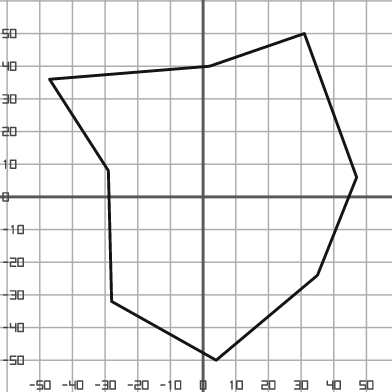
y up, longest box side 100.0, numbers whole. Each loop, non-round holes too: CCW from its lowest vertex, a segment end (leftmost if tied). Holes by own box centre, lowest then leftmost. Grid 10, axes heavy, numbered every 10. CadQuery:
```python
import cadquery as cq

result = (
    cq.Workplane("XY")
    .moveTo(4.0, -50.0)
    .lineTo(35.0, -24.0)
    .lineTo(47.0, 6.0)
    .lineTo(31.0, 50.0)
    .lineTo(2.0, 40.0)
    .lineTo(-47.0, 36.0)
    .lineTo(-29.0, 8.0)
    .lineTo(-28.0, -32.0)
    .close()
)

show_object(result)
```